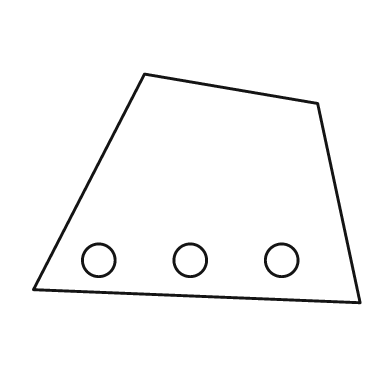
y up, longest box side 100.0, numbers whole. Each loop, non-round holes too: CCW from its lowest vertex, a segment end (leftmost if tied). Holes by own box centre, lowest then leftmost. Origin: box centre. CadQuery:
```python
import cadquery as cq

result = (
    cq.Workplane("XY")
    .moveTo(50.0, -35.0)
    .lineTo(37.0, 26.0)
    .lineTo(-16.0, 35.0)
    .lineTo(-50.0, -31.0)
    .close()
    .moveTo(-30.0, -22.0)
    .circle(5.0)
    .moveTo(-2.0, -22.0)
    .circle(5.0)
    .moveTo(26.0, -22.0)
    .circle(5.0)
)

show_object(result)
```